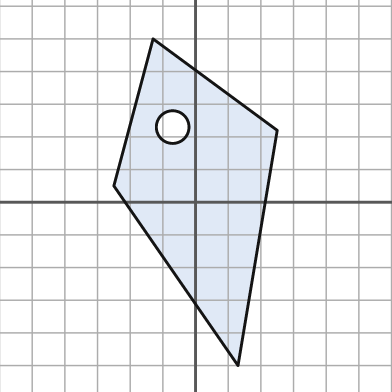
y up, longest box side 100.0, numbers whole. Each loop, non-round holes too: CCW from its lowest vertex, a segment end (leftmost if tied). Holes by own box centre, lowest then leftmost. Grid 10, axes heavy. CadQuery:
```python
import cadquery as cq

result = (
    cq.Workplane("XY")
    .moveTo(13.0, -50.0)
    .lineTo(25.0, 22.0)
    .lineTo(-13.0, 50.0)
    .lineTo(-25.0, 5.0)
    .close()
    .moveTo(-7.0, 23.0)
    .circle(5.0)
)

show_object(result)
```